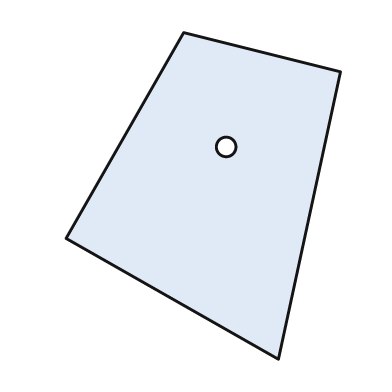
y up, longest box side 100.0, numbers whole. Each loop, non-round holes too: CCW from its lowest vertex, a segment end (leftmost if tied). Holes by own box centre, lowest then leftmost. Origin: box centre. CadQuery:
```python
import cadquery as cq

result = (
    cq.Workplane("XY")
    .moveTo(23.0, -50.0)
    .lineTo(42.0, 38.0)
    .lineTo(-6.0, 50.0)
    .lineTo(-42.0, -13.0)
    .close()
    .moveTo(7.0, 15.0)
    .circle(3.0)
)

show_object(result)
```